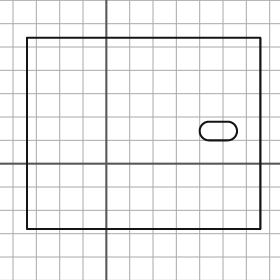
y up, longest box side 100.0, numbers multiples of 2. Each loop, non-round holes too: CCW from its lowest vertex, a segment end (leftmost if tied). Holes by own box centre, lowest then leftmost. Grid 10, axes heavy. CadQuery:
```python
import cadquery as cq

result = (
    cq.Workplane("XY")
    .moveTo(-34.0, -28.0)
    .lineTo(66.0, -28.0)
    .lineTo(66.0, 54.0)
    .lineTo(-34.0, 54.0)
    .close()
    .moveTo(44.0, 10.0)
    .lineTo(52.0, 10.0)
    .threePointArc((56.0, 14.0), (52.0, 18.0))
    .lineTo(44.0, 18.0)
    .threePointArc((40.0, 14.0), (44.0, 10.0))
    .close()
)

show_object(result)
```